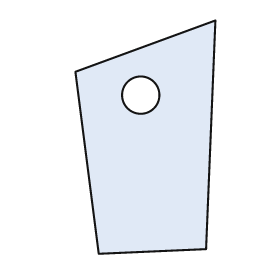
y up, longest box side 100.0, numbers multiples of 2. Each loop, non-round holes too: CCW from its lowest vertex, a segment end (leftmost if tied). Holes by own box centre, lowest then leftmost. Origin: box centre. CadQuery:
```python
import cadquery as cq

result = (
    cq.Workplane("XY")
    .moveTo(-20.0, -50.0)
    .lineTo(26.0, -48.0)
    .lineTo(30.0, 50.0)
    .lineTo(-30.0, 28.0)
    .close()
    .moveTo(-2.0, 18.0)
    .circle(8.0)
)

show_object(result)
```